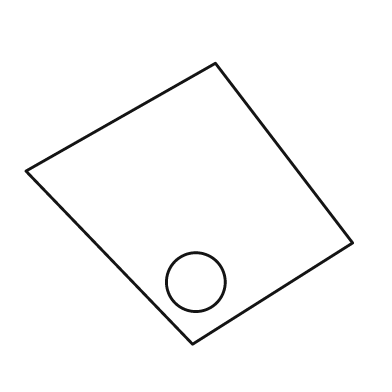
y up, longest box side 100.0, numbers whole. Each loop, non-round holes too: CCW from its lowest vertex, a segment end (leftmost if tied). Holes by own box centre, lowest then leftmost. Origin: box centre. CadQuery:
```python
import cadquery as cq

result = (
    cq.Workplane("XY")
    .moveTo(1.0, -43.0)
    .lineTo(50.0, -12.0)
    .lineTo(8.0, 43.0)
    .lineTo(-50.0, 10.0)
    .close()
    .moveTo(2.0, -24.0)
    .circle(9.0)
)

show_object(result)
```